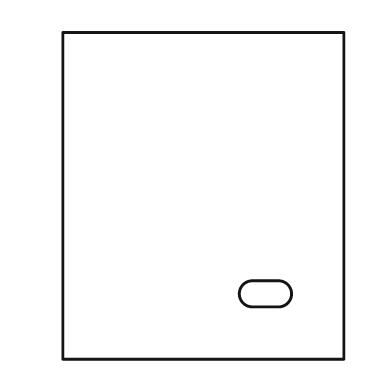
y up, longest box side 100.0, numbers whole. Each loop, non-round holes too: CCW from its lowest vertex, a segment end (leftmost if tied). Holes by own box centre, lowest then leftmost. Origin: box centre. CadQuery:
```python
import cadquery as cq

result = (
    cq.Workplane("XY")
    .moveTo(-43.0, -50.0)
    .lineTo(43.0, -50.0)
    .lineTo(43.0, 50.0)
    .lineTo(-43.0, 50.0)
    .close()
    .moveTo(15.0, -34.0)
    .lineTo(23.0, -34.0)
    .threePointArc((27.0, -30.0), (23.0, -26.0))
    .lineTo(15.0, -26.0)
    .threePointArc((11.0, -30.0), (15.0, -34.0))
    .close()
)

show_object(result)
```